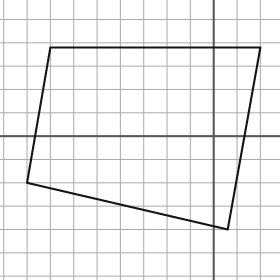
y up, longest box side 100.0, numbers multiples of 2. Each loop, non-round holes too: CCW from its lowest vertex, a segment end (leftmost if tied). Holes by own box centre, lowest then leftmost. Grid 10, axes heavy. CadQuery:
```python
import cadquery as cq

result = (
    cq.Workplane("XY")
    .moveTo(6.0, -40.0)
    .lineTo(20.0, 38.0)
    .lineTo(-70.0, 38.0)
    .lineTo(-80.0, -20.0)
    .close()
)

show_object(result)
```